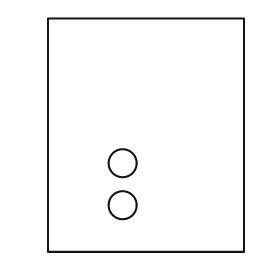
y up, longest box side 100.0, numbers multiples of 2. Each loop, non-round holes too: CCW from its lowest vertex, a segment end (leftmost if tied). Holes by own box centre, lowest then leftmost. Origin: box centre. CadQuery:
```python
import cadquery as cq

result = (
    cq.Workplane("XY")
    .moveTo(-42.0, -50.0)
    .lineTo(42.0, -50.0)
    .lineTo(42.0, 50.0)
    .lineTo(-42.0, 50.0)
    .close()
    .moveTo(-10.0, -30.0)
    .circle(6.0)
    .moveTo(-10.0, -12.0)
    .circle(6.0)
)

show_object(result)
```